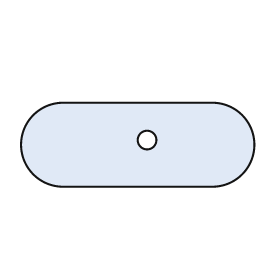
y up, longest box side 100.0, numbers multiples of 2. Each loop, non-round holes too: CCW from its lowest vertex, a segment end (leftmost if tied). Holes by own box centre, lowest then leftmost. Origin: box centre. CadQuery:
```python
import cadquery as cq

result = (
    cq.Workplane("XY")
    .moveTo(-32.0, -18.0)
    .lineTo(32.0, -18.0)
    .threePointArc((50.0, 0.0), (32.0, 18.0))
    .lineTo(-32.0, 18.0)
    .threePointArc((-50.0, 0.0), (-32.0, -18.0))
    .close()
    .moveTo(4.0, 2.0)
    .circle(4.0)
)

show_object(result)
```